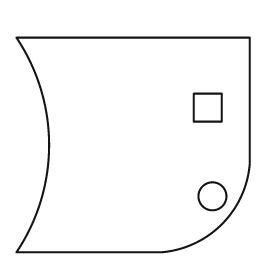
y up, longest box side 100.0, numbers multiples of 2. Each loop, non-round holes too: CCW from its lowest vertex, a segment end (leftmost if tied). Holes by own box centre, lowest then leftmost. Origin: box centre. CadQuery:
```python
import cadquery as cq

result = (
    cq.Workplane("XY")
    .moveTo(-50.0, -46.0)
    .lineTo(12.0, -46.0)
    .threePointArc((38.0, -34.0), (50.0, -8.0))
    .lineTo(50.0, 46.0)
    .lineTo(-50.0, 46.0)
    .threePointArc((-36.0, 0.0), (-50.0, -46.0))
    .close()
    .moveTo(34.0, -22.0)
    .circle(6.0)
    .moveTo(26.0, 10.0)
    .lineTo(38.0, 10.0)
    .lineTo(38.0, 22.0)
    .lineTo(26.0, 22.0)
    .close()
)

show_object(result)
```